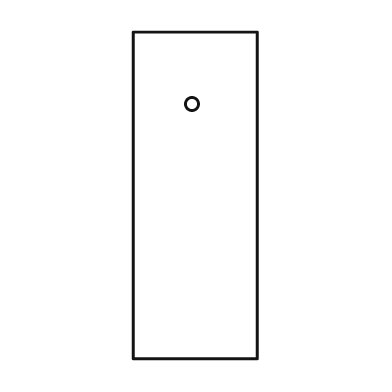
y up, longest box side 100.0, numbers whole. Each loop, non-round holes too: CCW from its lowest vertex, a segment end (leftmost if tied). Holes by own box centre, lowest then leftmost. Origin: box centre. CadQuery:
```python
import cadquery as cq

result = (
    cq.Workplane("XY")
    .moveTo(-19.0, -50.0)
    .lineTo(19.0, -50.0)
    .lineTo(19.0, 50.0)
    .lineTo(-19.0, 50.0)
    .close()
    .moveTo(-1.0, 28.0)
    .circle(2.0)
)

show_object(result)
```